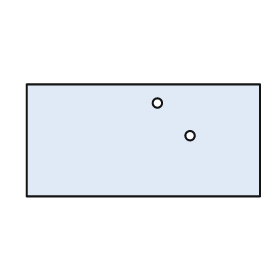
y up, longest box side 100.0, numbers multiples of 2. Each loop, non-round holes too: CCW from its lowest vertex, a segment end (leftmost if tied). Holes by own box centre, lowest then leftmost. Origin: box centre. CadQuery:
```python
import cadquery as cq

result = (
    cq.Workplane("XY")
    .moveTo(-50.0, -24.0)
    .lineTo(50.0, -24.0)
    .lineTo(50.0, 24.0)
    .lineTo(-50.0, 24.0)
    .close()
    .moveTo(20.0, 2.0)
    .circle(2.0)
    .moveTo(6.0, 16.0)
    .circle(2.0)
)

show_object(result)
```